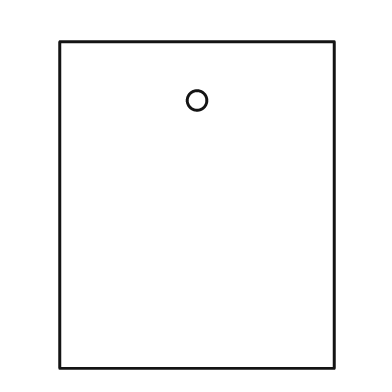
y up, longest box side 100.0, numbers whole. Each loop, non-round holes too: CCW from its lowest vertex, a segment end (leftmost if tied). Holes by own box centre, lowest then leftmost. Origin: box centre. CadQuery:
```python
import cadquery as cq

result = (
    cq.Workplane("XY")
    .moveTo(-42.0, -50.0)
    .lineTo(42.0, -50.0)
    .lineTo(42.0, 50.0)
    .lineTo(-42.0, 50.0)
    .close()
    .moveTo(0.0, 32.0)
    .circle(3.0)
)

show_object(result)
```